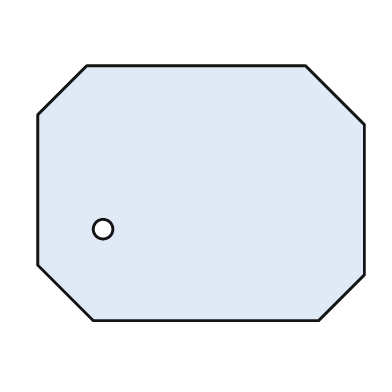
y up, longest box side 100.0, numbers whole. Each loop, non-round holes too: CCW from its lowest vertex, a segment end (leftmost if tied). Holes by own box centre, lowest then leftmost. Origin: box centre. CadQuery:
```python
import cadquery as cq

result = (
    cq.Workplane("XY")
    .moveTo(-33.0, -39.0)
    .lineTo(36.0, -39.0)
    .lineTo(50.0, -25.0)
    .lineTo(50.0, 21.0)
    .lineTo(32.0, 39.0)
    .lineTo(-35.0, 39.0)
    .lineTo(-50.0, 24.0)
    .lineTo(-50.0, -22.0)
    .close()
    .moveTo(-30.0, -11.0)
    .circle(3.0)
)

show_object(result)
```